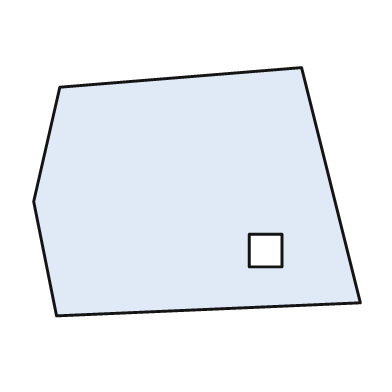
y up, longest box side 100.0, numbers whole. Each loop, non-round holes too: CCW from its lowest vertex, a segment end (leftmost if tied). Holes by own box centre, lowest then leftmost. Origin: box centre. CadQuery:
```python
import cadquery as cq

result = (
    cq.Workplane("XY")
    .moveTo(-43.0, -38.0)
    .lineTo(50.0, -34.0)
    .lineTo(32.0, 38.0)
    .lineTo(-42.0, 32.0)
    .lineTo(-50.0, -3.0)
    .close()
    .moveTo(16.0, -23.0)
    .lineTo(26.0, -23.0)
    .lineTo(26.0, -13.0)
    .lineTo(16.0, -13.0)
    .close()
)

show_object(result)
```